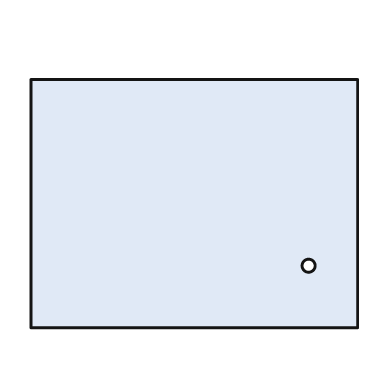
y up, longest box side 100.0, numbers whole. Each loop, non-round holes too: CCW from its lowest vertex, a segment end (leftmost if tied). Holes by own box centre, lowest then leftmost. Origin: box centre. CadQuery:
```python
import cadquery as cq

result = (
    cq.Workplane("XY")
    .moveTo(-50.0, -38.0)
    .lineTo(50.0, -38.0)
    .lineTo(50.0, 38.0)
    .lineTo(-50.0, 38.0)
    .close()
    .moveTo(35.0, -19.0)
    .circle(2.0)
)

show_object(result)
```